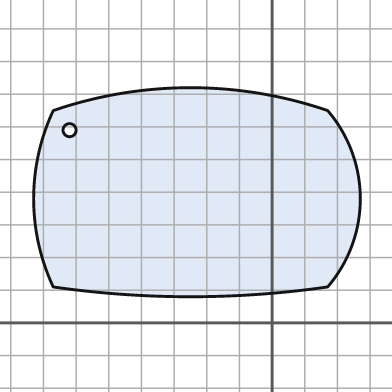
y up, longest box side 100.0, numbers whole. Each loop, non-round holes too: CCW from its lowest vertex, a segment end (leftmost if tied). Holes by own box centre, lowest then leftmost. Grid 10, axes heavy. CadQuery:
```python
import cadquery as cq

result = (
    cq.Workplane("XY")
    .moveTo(-67.0, 11.0)
    .threePointArc((-25.0, 8.0), (17.0, 11.0))
    .threePointArc((27.0, 38.0), (17.0, 65.0))
    .threePointArc((-25.0, 72.0), (-67.0, 65.0))
    .threePointArc((-73.0, 38.0), (-67.0, 11.0))
    .close()
    .moveTo(-62.0, 59.0)
    .circle(2.0)
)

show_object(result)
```